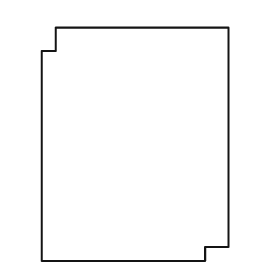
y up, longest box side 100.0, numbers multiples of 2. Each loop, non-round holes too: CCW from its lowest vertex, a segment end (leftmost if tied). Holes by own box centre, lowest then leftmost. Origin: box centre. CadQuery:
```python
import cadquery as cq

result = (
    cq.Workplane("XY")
    .moveTo(-40.0, -50.0)
    .lineTo(30.0, -50.0)
    .lineTo(30.0, -44.0)
    .lineTo(40.0, -44.0)
    .lineTo(40.0, 50.0)
    .lineTo(-34.0, 50.0)
    .lineTo(-34.0, 40.0)
    .lineTo(-40.0, 40.0)
    .close()
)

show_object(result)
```